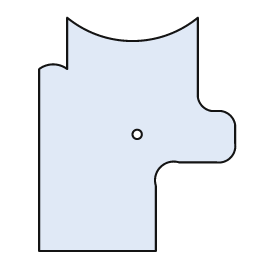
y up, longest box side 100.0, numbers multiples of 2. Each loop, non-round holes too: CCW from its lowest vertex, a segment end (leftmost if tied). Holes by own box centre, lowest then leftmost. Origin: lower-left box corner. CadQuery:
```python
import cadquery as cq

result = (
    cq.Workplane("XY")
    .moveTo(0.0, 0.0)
    .lineTo(50.0, 0.0)
    .lineTo(50.0, 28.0)
    .threePointArc((52.0, 36.0), (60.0, 38.0))
    .lineTo(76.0, 38.0)
    .threePointArc((82.0, 40.0), (84.0, 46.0))
    .lineTo(84.0, 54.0)
    .threePointArc((82.0, 58.0), (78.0, 60.0))
    .lineTo(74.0, 60.0)
    .threePointArc((70.0, 62.0), (68.0, 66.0))
    .lineTo(68.0, 100.0)
    .threePointArc((40.0, 90.0), (12.0, 100.0))
    .lineTo(12.0, 78.0)
    .threePointArc((6.0, 80.0), (0.0, 78.0))
    .close()
    .moveTo(42.0, 50.0)
    .circle(2.0)
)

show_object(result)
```